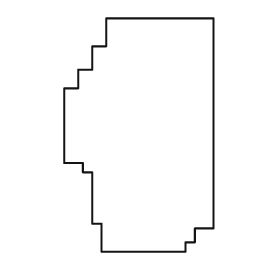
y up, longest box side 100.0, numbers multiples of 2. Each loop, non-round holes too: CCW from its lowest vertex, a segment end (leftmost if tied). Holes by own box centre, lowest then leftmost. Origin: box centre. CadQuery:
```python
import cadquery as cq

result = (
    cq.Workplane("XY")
    .moveTo(-16.0, -50.0)
    .lineTo(20.0, -50.0)
    .lineTo(20.0, -46.0)
    .lineTo(24.0, -46.0)
    .lineTo(24.0, -40.0)
    .lineTo(32.0, -40.0)
    .lineTo(32.0, 50.0)
    .lineTo(-14.0, 50.0)
    .lineTo(-14.0, 38.0)
    .lineTo(-20.0, 38.0)
    .lineTo(-20.0, 28.0)
    .lineTo(-26.0, 28.0)
    .lineTo(-26.0, 20.0)
    .lineTo(-32.0, 20.0)
    .lineTo(-32.0, -12.0)
    .lineTo(-24.0, -12.0)
    .lineTo(-24.0, -16.0)
    .lineTo(-20.0, -16.0)
    .lineTo(-20.0, -38.0)
    .lineTo(-16.0, -38.0)
    .close()
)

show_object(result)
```